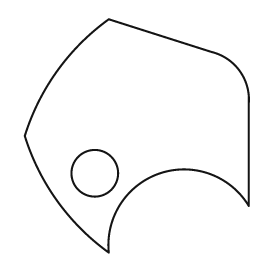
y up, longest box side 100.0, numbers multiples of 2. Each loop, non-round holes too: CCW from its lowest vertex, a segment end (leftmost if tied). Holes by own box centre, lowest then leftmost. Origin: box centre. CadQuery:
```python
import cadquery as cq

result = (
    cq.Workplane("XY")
    .moveTo(-12.0, -50.0)
    .threePointArc((10.0, -16.0), (48.0, -30.0))
    .lineTo(48.0, 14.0)
    .threePointArc((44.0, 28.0), (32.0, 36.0))
    .lineTo(-12.0, 50.0)
    .threePointArc((-34.0, 28.0), (-48.0, 0.0))
    .threePointArc((-34.0, -28.0), (-12.0, -50.0))
    .close()
    .moveTo(-18.0, -16.0)
    .circle(10.0)
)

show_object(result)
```